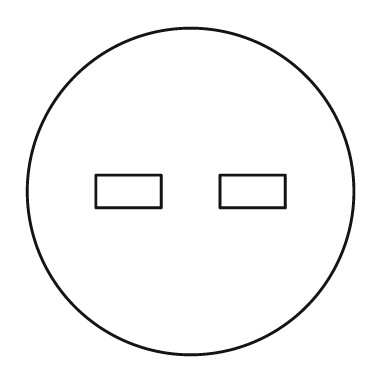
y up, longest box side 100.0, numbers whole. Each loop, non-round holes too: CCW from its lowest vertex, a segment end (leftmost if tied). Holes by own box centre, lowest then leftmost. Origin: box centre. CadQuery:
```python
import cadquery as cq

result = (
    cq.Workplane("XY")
    .moveTo(0.0, 0.0)
    .circle(50.0)
    .moveTo(-29.0, -5.0)
    .lineTo(-9.0, -5.0)
    .lineTo(-9.0, 5.0)
    .lineTo(-29.0, 5.0)
    .close()
    .moveTo(9.0, -5.0)
    .lineTo(29.0, -5.0)
    .lineTo(29.0, 5.0)
    .lineTo(9.0, 5.0)
    .close()
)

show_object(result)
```